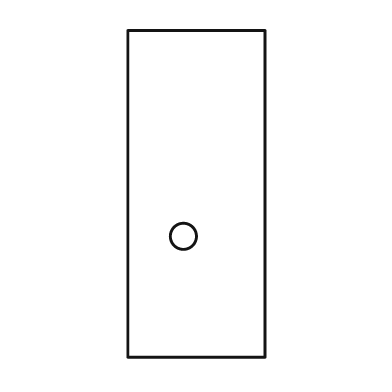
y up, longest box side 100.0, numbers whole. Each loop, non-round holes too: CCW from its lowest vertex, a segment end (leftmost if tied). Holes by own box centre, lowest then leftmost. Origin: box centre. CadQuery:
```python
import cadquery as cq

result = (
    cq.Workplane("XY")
    .moveTo(-21.0, -50.0)
    .lineTo(21.0, -50.0)
    .lineTo(21.0, 50.0)
    .lineTo(-21.0, 50.0)
    .close()
    .moveTo(-4.0, -13.0)
    .circle(4.0)
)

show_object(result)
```